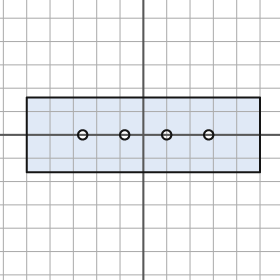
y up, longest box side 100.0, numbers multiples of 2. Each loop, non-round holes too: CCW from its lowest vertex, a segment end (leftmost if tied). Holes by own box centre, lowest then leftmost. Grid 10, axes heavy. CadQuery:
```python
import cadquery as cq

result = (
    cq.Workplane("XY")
    .moveTo(-50.0, -16.0)
    .lineTo(50.0, -16.0)
    .lineTo(50.0, 16.0)
    .lineTo(-50.0, 16.0)
    .close()
    .moveTo(-26.0, 0.0)
    .circle(2.0)
    .moveTo(-8.0, 0.0)
    .circle(2.0)
    .moveTo(10.0, 0.0)
    .circle(2.0)
    .moveTo(28.0, 0.0)
    .circle(2.0)
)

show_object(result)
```